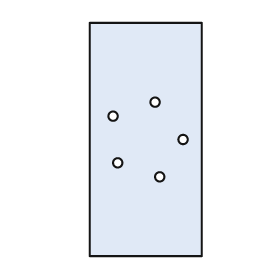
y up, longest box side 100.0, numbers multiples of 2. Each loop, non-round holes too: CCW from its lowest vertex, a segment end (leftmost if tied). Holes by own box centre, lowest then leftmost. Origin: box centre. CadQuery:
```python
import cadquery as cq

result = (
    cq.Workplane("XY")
    .moveTo(-24.0, -50.0)
    .lineTo(24.0, -50.0)
    .lineTo(24.0, 50.0)
    .lineTo(-24.0, 50.0)
    .close()
    .moveTo(6.0, -16.0)
    .circle(2.0)
    .moveTo(-12.0, -10.0)
    .circle(2.0)
    .moveTo(16.0, 0.0)
    .circle(2.0)
    .moveTo(-14.0, 10.0)
    .circle(2.0)
    .moveTo(4.0, 16.0)
    .circle(2.0)
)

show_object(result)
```